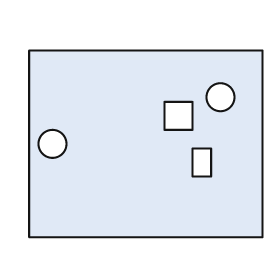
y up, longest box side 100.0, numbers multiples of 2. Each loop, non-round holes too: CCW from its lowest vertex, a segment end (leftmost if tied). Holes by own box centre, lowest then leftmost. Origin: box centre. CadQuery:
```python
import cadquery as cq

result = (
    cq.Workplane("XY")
    .moveTo(-50.0, -40.0)
    .lineTo(50.0, -40.0)
    .lineTo(50.0, 40.0)
    .lineTo(-50.0, 40.0)
    .close()
    .moveTo(20.0, -14.0)
    .lineTo(28.0, -14.0)
    .lineTo(28.0, -2.0)
    .lineTo(20.0, -2.0)
    .close()
    .moveTo(-40.0, 0.0)
    .circle(6.0)
    .moveTo(8.0, 6.0)
    .lineTo(20.0, 6.0)
    .lineTo(20.0, 18.0)
    .lineTo(8.0, 18.0)
    .close()
    .moveTo(32.0, 20.0)
    .circle(6.0)
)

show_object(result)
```